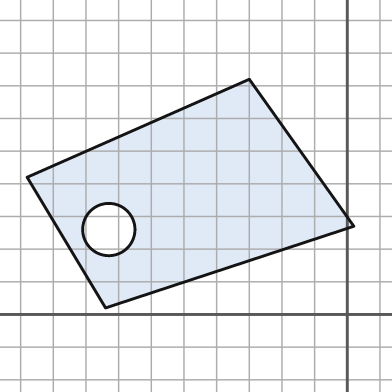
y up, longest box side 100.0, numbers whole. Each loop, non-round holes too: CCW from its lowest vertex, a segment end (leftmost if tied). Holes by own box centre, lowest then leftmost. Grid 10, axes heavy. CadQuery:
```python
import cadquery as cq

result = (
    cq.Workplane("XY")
    .moveTo(-74.0, 2.0)
    .lineTo(2.0, 27.0)
    .lineTo(-30.0, 72.0)
    .lineTo(-98.0, 42.0)
    .close()
    .moveTo(-73.0, 26.0)
    .circle(8.0)
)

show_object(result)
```